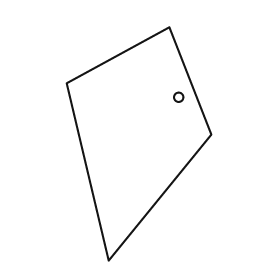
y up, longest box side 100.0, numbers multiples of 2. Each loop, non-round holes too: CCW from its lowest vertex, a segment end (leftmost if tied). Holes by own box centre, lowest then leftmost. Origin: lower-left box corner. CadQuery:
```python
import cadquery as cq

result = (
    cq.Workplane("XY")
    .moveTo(18.0, 0.0)
    .lineTo(62.0, 54.0)
    .lineTo(44.0, 100.0)
    .lineTo(0.0, 76.0)
    .close()
    .moveTo(48.0, 70.0)
    .circle(2.0)
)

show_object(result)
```